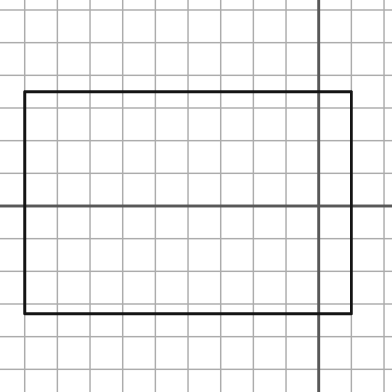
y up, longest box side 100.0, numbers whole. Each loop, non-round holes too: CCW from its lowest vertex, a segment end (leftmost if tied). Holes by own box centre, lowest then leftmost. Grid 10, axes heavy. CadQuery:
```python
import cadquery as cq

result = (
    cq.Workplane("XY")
    .moveTo(-90.0, -33.0)
    .lineTo(10.0, -33.0)
    .lineTo(10.0, 35.0)
    .lineTo(-90.0, 35.0)
    .close()
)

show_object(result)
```